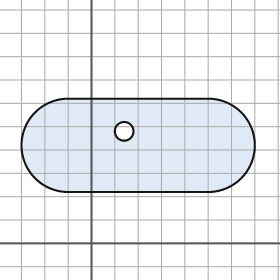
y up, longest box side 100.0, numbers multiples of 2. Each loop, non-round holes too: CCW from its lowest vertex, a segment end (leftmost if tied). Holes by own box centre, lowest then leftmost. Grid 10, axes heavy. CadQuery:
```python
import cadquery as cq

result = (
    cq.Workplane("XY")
    .moveTo(-10.0, 22.0)
    .lineTo(50.0, 22.0)
    .threePointArc((70.0, 42.0), (50.0, 62.0))
    .lineTo(-10.0, 62.0)
    .threePointArc((-30.0, 42.0), (-10.0, 22.0))
    .close()
    .moveTo(14.0, 48.0)
    .circle(4.0)
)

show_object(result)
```